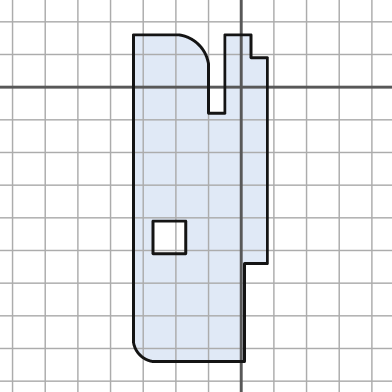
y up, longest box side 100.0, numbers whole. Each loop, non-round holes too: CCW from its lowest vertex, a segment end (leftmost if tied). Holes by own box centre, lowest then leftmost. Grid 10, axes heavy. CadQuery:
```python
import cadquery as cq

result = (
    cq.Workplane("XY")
    .moveTo(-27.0, -84.0)
    .lineTo(1.0, -84.0)
    .lineTo(1.0, -54.0)
    .lineTo(8.0, -54.0)
    .lineTo(8.0, 9.0)
    .lineTo(3.0, 9.0)
    .lineTo(3.0, 16.0)
    .lineTo(-5.0, 16.0)
    .lineTo(-5.0, -8.0)
    .lineTo(-10.0, -8.0)
    .lineTo(-10.0, 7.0)
    .threePointArc((-13.0, 13.0), (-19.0, 16.0))
    .lineTo(-33.0, 16.0)
    .lineTo(-33.0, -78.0)
    .threePointArc((-31.0, -82.0), (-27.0, -84.0))
    .close()
    .moveTo(-27.0, -51.0)
    .lineTo(-17.0, -51.0)
    .lineTo(-17.0, -41.0)
    .lineTo(-27.0, -41.0)
    .close()
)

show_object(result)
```